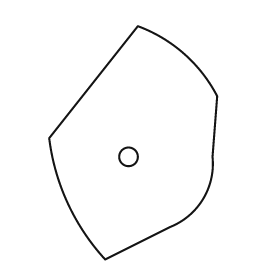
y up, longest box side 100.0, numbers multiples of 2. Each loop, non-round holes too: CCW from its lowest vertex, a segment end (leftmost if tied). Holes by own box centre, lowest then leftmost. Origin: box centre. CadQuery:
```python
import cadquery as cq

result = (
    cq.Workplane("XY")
    .moveTo(-12.0, -50.0)
    .lineTo(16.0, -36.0)
    .threePointArc((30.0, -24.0), (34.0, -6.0))
    .lineTo(36.0, 20.0)
    .threePointArc((22.0, 38.0), (2.0, 50.0))
    .lineTo(-36.0, 2.0)
    .threePointArc((-28.0, -26.0), (-12.0, -50.0))
    .close()
    .moveTo(-2.0, -6.0)
    .circle(4.0)
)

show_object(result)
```